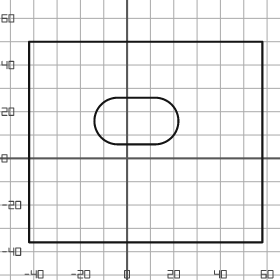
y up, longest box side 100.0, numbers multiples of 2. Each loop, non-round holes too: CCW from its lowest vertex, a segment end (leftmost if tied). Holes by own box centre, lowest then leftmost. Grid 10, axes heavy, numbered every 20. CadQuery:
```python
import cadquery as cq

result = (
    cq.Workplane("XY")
    .moveTo(-42.0, -36.0)
    .lineTo(58.0, -36.0)
    .lineTo(58.0, 50.0)
    .lineTo(-42.0, 50.0)
    .close()
    .moveTo(-4.0, 6.0)
    .lineTo(12.0, 6.0)
    .threePointArc((22.0, 16.0), (12.0, 26.0))
    .lineTo(-4.0, 26.0)
    .threePointArc((-14.0, 16.0), (-4.0, 6.0))
    .close()
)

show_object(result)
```